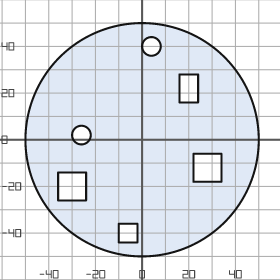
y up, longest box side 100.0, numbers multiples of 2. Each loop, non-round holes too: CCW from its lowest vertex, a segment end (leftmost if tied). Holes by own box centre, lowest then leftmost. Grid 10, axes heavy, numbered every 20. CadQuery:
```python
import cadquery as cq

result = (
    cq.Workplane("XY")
    .moveTo(0.0, 0.0)
    .circle(50.0)
    .moveTo(-10.0, -44.0)
    .lineTo(-2.0, -44.0)
    .lineTo(-2.0, -36.0)
    .lineTo(-10.0, -36.0)
    .close()
    .moveTo(-36.0, -26.0)
    .lineTo(-24.0, -26.0)
    .lineTo(-24.0, -14.0)
    .lineTo(-36.0, -14.0)
    .close()
    .moveTo(22.0, -18.0)
    .lineTo(34.0, -18.0)
    .lineTo(34.0, -6.0)
    .lineTo(22.0, -6.0)
    .close()
    .moveTo(-26.0, 2.0)
    .circle(4.0)
    .moveTo(16.0, 16.0)
    .lineTo(24.0, 16.0)
    .lineTo(24.0, 28.0)
    .lineTo(16.0, 28.0)
    .close()
    .moveTo(4.0, 40.0)
    .circle(4.0)
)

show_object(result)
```